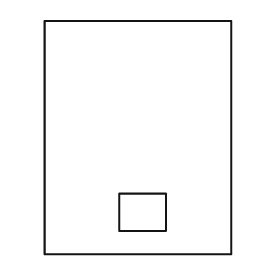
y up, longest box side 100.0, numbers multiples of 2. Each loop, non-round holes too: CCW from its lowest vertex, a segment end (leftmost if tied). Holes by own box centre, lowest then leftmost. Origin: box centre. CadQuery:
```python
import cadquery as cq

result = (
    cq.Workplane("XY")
    .moveTo(-40.0, -50.0)
    .lineTo(40.0, -50.0)
    .lineTo(40.0, 50.0)
    .lineTo(-40.0, 50.0)
    .close()
    .moveTo(-8.0, -40.0)
    .lineTo(12.0, -40.0)
    .lineTo(12.0, -24.0)
    .lineTo(-8.0, -24.0)
    .close()
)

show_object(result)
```